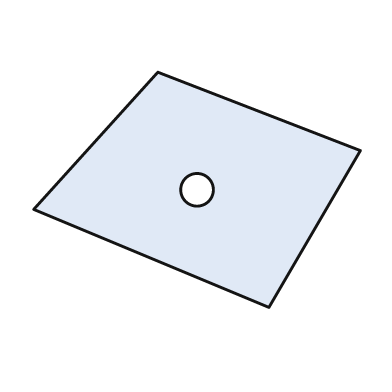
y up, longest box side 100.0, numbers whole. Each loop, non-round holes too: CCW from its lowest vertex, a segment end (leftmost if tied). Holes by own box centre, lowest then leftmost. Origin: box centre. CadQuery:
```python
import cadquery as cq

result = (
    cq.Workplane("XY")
    .moveTo(22.0, -36.0)
    .lineTo(50.0, 12.0)
    .lineTo(-12.0, 36.0)
    .lineTo(-50.0, -6.0)
    .close()
    .moveTo(0.0, 0.0)
    .circle(5.0)
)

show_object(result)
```